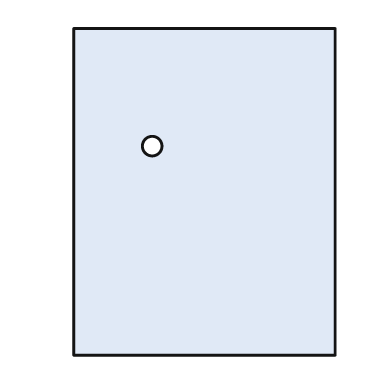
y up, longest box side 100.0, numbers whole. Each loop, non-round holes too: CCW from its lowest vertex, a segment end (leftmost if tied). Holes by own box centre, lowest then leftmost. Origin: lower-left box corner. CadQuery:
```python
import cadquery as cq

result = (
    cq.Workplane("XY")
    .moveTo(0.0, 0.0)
    .lineTo(80.0, 0.0)
    .lineTo(80.0, 100.0)
    .lineTo(0.0, 100.0)
    .close()
    .moveTo(24.0, 64.0)
    .circle(3.0)
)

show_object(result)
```